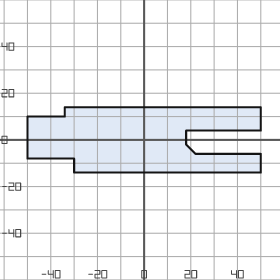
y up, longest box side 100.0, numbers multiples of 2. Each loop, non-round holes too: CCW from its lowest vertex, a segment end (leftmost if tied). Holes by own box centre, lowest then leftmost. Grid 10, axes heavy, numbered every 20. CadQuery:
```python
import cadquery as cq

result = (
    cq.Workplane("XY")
    .moveTo(-30.0, -14.0)
    .lineTo(50.0, -14.0)
    .lineTo(50.0, -6.0)
    .lineTo(22.0, -6.0)
    .lineTo(18.0, -2.0)
    .lineTo(18.0, 4.0)
    .lineTo(50.0, 4.0)
    .lineTo(50.0, 14.0)
    .lineTo(-34.0, 14.0)
    .lineTo(-34.0, 10.0)
    .lineTo(-50.0, 10.0)
    .lineTo(-50.0, -8.0)
    .lineTo(-30.0, -8.0)
    .close()
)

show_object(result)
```